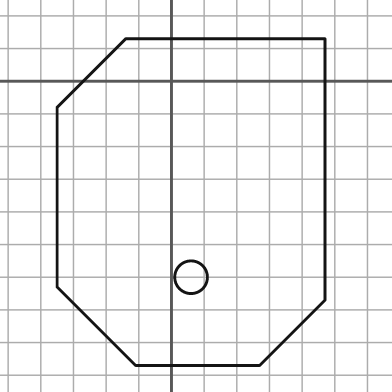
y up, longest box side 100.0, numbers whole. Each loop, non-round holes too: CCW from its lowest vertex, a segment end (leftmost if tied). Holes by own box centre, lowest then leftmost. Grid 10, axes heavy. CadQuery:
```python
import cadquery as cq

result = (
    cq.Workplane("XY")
    .moveTo(-11.0, -87.0)
    .lineTo(27.0, -87.0)
    .lineTo(47.0, -67.0)
    .lineTo(47.0, 13.0)
    .lineTo(-14.0, 13.0)
    .lineTo(-35.0, -8.0)
    .lineTo(-35.0, -63.0)
    .close()
    .moveTo(6.0, -60.0)
    .circle(5.0)
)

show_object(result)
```